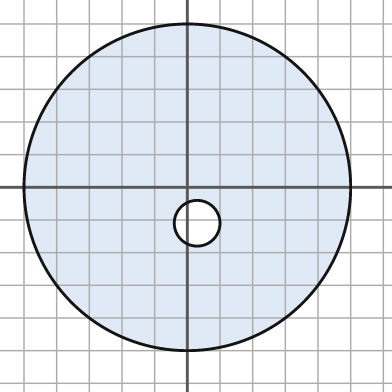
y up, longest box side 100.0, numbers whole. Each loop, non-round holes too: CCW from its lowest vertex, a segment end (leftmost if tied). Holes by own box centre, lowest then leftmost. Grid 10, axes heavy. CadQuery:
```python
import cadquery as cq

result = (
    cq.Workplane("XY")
    .moveTo(0.0, 0.0)
    .circle(50.0)
    .moveTo(3.0, -11.0)
    .circle(7.0)
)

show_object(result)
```